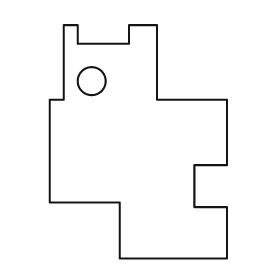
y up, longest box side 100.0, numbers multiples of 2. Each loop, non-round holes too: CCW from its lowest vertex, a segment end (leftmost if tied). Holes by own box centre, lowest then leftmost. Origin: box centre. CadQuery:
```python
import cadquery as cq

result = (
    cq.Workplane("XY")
    .moveTo(-8.0, -50.0)
    .lineTo(38.0, -50.0)
    .lineTo(38.0, -28.0)
    .lineTo(24.0, -28.0)
    .lineTo(24.0, -10.0)
    .lineTo(38.0, -10.0)
    .lineTo(38.0, 18.0)
    .lineTo(8.0, 18.0)
    .lineTo(8.0, 50.0)
    .lineTo(-4.0, 50.0)
    .lineTo(-4.0, 42.0)
    .lineTo(-26.0, 42.0)
    .lineTo(-26.0, 50.0)
    .lineTo(-32.0, 50.0)
    .lineTo(-32.0, 18.0)
    .lineTo(-38.0, 18.0)
    .lineTo(-38.0, -26.0)
    .lineTo(-8.0, -26.0)
    .close()
    .moveTo(-20.0, 26.0)
    .circle(6.0)
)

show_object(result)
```